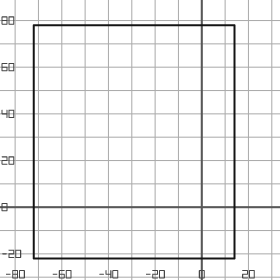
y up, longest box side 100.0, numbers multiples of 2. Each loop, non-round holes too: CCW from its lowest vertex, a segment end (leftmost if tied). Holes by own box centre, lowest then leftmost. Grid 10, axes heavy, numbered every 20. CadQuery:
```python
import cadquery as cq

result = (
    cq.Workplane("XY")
    .moveTo(-72.0, -22.0)
    .lineTo(14.0, -22.0)
    .lineTo(14.0, 78.0)
    .lineTo(-72.0, 78.0)
    .close()
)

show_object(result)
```